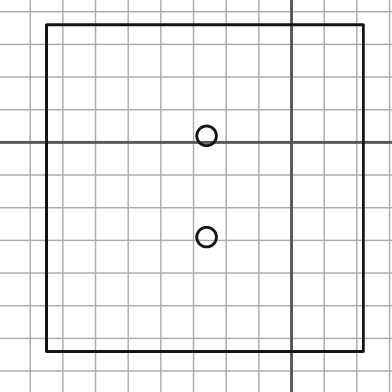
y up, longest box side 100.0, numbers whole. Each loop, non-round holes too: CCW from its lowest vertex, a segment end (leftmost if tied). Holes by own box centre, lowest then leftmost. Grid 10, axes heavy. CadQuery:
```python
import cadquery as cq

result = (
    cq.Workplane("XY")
    .moveTo(-75.0, -64.0)
    .lineTo(22.0, -64.0)
    .lineTo(22.0, 36.0)
    .lineTo(-75.0, 36.0)
    .close()
    .moveTo(-26.0, -29.0)
    .circle(3.0)
    .moveTo(-26.0, 2.0)
    .circle(3.0)
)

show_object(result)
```